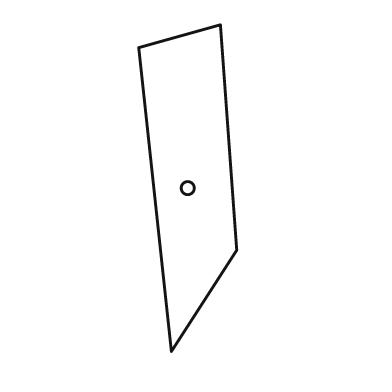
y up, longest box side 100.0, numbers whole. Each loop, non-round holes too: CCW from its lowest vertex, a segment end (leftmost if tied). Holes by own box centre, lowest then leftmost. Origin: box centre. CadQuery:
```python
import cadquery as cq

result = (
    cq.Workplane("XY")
    .moveTo(-5.0, -50.0)
    .lineTo(15.0, -19.0)
    .lineTo(10.0, 50.0)
    .lineTo(-15.0, 43.0)
    .close()
    .moveTo(0.0, 0.0)
    .circle(2.0)
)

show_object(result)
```